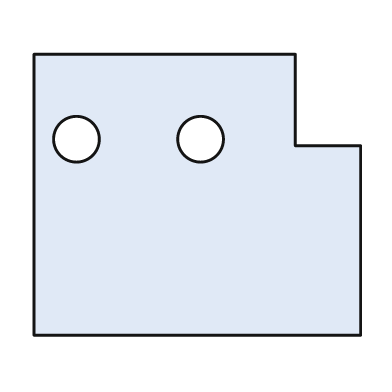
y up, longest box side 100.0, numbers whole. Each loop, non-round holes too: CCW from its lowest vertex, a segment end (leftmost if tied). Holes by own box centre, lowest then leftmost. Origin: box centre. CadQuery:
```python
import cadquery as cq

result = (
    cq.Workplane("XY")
    .moveTo(-50.0, -43.0)
    .lineTo(50.0, -43.0)
    .lineTo(50.0, 15.0)
    .lineTo(30.0, 15.0)
    .lineTo(30.0, 43.0)
    .lineTo(-50.0, 43.0)
    .close()
    .moveTo(-37.0, 17.0)
    .circle(7.0)
    .moveTo(1.0, 17.0)
    .circle(7.0)
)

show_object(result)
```